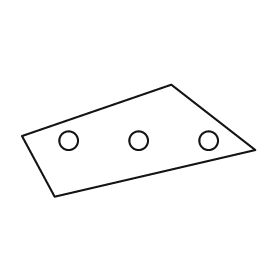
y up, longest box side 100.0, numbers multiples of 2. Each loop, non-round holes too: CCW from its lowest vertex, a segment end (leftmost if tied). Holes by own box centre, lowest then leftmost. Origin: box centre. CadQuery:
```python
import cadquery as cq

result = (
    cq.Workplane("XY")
    .moveTo(-36.0, -24.0)
    .lineTo(50.0, -4.0)
    .lineTo(14.0, 24.0)
    .lineTo(-50.0, 2.0)
    .close()
    .moveTo(-30.0, 0.0)
    .circle(4.0)
    .moveTo(0.0, 0.0)
    .circle(4.0)
    .moveTo(30.0, 0.0)
    .circle(4.0)
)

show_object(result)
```